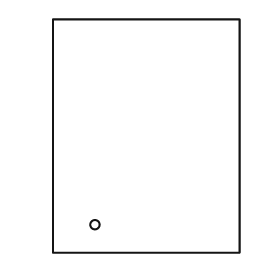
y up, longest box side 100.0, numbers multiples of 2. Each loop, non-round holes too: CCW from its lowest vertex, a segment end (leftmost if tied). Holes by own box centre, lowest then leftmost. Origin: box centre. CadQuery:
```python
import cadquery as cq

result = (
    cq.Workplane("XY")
    .moveTo(-40.0, -50.0)
    .lineTo(40.0, -50.0)
    .lineTo(40.0, 50.0)
    .lineTo(-40.0, 50.0)
    .close()
    .moveTo(-22.0, -38.0)
    .circle(2.0)
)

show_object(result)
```